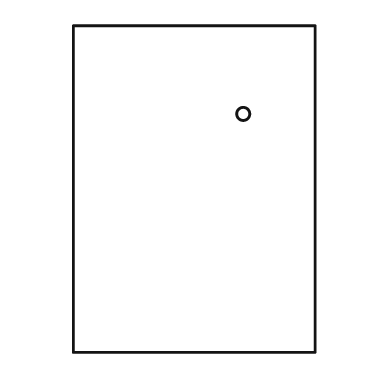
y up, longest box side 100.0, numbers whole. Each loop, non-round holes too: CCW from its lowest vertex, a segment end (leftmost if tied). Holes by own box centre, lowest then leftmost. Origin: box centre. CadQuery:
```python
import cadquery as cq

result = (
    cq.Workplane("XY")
    .moveTo(-37.0, -50.0)
    .lineTo(37.0, -50.0)
    .lineTo(37.0, 50.0)
    .lineTo(-37.0, 50.0)
    .close()
    .moveTo(15.0, 23.0)
    .circle(2.0)
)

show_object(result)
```